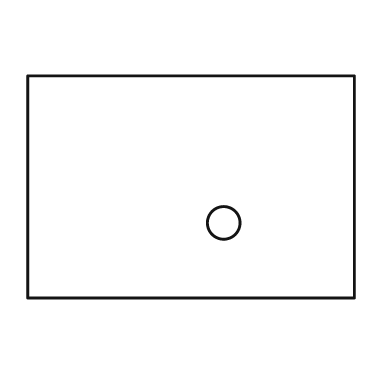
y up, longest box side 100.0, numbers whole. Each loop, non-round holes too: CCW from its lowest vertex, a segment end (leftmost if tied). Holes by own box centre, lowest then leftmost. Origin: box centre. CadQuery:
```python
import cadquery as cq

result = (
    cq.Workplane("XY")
    .moveTo(-50.0, -34.0)
    .lineTo(50.0, -34.0)
    .lineTo(50.0, 34.0)
    .lineTo(-50.0, 34.0)
    .close()
    .moveTo(10.0, -11.0)
    .circle(5.0)
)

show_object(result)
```